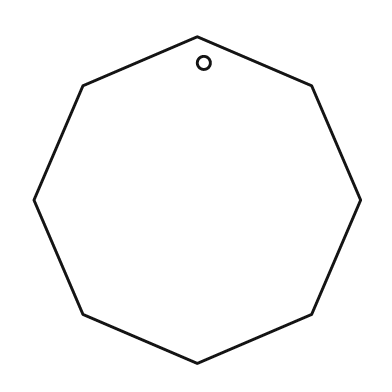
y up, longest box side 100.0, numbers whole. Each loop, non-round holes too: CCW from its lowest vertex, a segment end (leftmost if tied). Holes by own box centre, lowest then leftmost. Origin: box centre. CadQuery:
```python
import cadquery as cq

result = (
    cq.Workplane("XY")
    .moveTo(0.0, -50.0)
    .lineTo(35.0, -35.0)
    .lineTo(50.0, 0.0)
    .lineTo(35.0, 35.0)
    .lineTo(0.0, 50.0)
    .lineTo(-35.0, 35.0)
    .lineTo(-50.0, 0.0)
    .lineTo(-35.0, -35.0)
    .close()
    .moveTo(2.0, 42.0)
    .circle(2.0)
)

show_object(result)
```